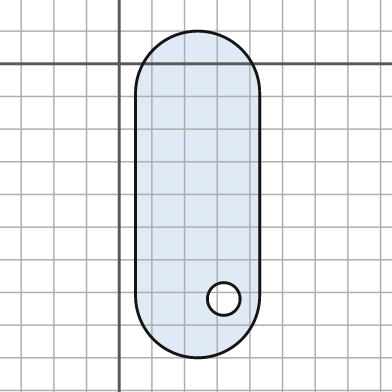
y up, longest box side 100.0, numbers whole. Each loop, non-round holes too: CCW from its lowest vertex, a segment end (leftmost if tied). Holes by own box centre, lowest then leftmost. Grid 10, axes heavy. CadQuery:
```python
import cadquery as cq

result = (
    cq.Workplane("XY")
    .moveTo(5.0, -71.0)
    .threePointArc((24.0, -90.0), (43.0, -71.0))
    .lineTo(43.0, -9.0)
    .threePointArc((24.0, 10.0), (5.0, -9.0))
    .close()
    .moveTo(32.0, -72.0)
    .circle(5.0)
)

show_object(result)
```